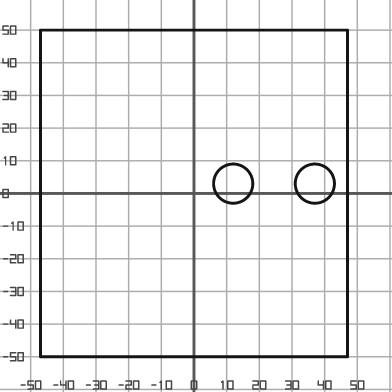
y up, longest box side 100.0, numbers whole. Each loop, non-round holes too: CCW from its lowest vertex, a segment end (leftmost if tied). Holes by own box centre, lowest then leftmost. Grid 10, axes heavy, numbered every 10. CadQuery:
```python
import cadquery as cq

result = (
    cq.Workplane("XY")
    .moveTo(-47.0, -50.0)
    .lineTo(47.0, -50.0)
    .lineTo(47.0, 50.0)
    .lineTo(-47.0, 50.0)
    .close()
    .moveTo(12.0, 3.0)
    .circle(6.0)
    .moveTo(37.0, 3.0)
    .circle(6.0)
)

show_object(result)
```